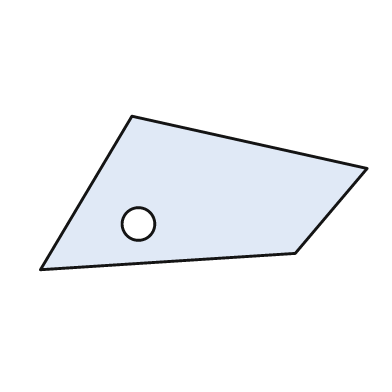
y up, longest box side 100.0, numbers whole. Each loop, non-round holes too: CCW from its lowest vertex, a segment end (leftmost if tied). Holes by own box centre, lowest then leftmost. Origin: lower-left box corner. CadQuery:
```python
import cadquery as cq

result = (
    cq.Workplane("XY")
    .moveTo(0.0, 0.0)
    .lineTo(78.0, 5.0)
    .lineTo(100.0, 31.0)
    .lineTo(28.0, 47.0)
    .close()
    .moveTo(30.0, 14.0)
    .circle(5.0)
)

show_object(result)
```